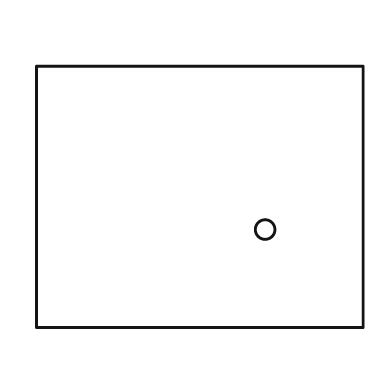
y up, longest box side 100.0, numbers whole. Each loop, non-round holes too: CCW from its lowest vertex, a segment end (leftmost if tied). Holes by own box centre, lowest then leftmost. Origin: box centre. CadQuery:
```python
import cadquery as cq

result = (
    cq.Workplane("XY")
    .moveTo(-50.0, -40.0)
    .lineTo(50.0, -40.0)
    .lineTo(50.0, 40.0)
    .lineTo(-50.0, 40.0)
    .close()
    .moveTo(20.0, -10.0)
    .circle(3.0)
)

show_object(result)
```